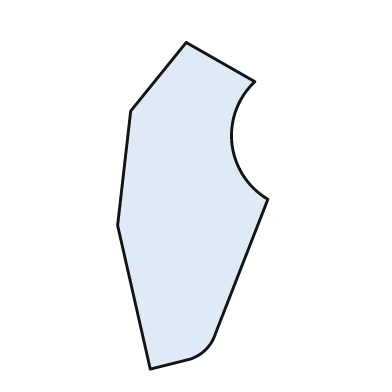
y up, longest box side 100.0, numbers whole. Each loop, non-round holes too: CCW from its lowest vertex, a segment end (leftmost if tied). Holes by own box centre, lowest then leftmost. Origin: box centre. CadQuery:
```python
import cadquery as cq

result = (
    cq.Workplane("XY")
    .moveTo(-13.0, -50.0)
    .lineTo(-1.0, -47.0)
    .threePointArc((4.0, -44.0), (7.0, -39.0))
    .lineTo(23.0, 2.0)
    .threePointArc((12.0, 19.0), (19.0, 38.0))
    .lineTo(-2.0, 50.0)
    .lineTo(-19.0, 29.0)
    .lineTo(-23.0, -6.0)
    .close()
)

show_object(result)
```